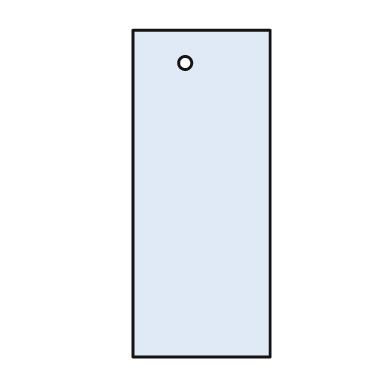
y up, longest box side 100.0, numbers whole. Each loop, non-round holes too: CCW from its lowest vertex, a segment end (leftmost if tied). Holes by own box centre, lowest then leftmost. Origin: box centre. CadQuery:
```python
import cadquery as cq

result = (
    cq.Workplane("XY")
    .moveTo(-21.0, -50.0)
    .lineTo(21.0, -50.0)
    .lineTo(21.0, 50.0)
    .lineTo(-21.0, 50.0)
    .close()
    .moveTo(-5.0, 40.0)
    .circle(2.0)
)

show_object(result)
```